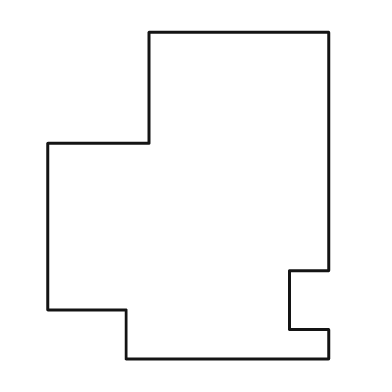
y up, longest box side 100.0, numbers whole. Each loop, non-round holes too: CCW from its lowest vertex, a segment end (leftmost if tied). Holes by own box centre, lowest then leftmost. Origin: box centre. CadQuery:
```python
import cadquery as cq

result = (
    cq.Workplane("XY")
    .moveTo(-19.0, -50.0)
    .lineTo(43.0, -50.0)
    .lineTo(43.0, -41.0)
    .lineTo(31.0, -41.0)
    .lineTo(31.0, -23.0)
    .lineTo(43.0, -23.0)
    .lineTo(43.0, 50.0)
    .lineTo(-12.0, 50.0)
    .lineTo(-12.0, 16.0)
    .lineTo(-43.0, 16.0)
    .lineTo(-43.0, -35.0)
    .lineTo(-19.0, -35.0)
    .close()
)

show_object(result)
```